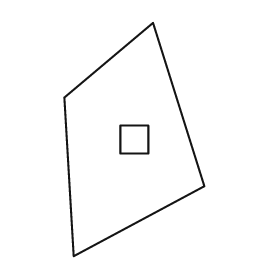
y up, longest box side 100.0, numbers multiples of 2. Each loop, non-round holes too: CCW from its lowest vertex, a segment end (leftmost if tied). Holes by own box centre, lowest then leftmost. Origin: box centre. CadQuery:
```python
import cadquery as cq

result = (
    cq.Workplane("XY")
    .moveTo(-26.0, -50.0)
    .lineTo(30.0, -20.0)
    .lineTo(8.0, 50.0)
    .lineTo(-30.0, 18.0)
    .close()
    .moveTo(-6.0, -6.0)
    .lineTo(6.0, -6.0)
    .lineTo(6.0, 6.0)
    .lineTo(-6.0, 6.0)
    .close()
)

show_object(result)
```